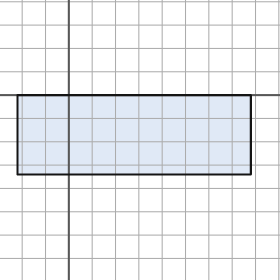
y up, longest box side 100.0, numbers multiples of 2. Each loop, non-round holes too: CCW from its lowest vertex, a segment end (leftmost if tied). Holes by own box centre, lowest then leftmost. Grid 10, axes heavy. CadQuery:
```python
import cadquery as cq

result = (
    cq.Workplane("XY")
    .moveTo(-22.0, -34.0)
    .lineTo(78.0, -34.0)
    .lineTo(78.0, 0.0)
    .lineTo(-22.0, 0.0)
    .close()
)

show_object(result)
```